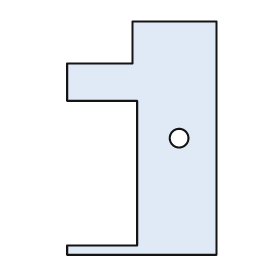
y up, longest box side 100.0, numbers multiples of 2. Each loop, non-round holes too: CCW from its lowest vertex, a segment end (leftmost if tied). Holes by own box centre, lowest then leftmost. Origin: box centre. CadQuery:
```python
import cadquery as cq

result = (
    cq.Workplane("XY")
    .moveTo(-32.0, -50.0)
    .lineTo(32.0, -50.0)
    .lineTo(32.0, 50.0)
    .lineTo(-4.0, 50.0)
    .lineTo(-4.0, 32.0)
    .lineTo(-32.0, 32.0)
    .lineTo(-32.0, 16.0)
    .lineTo(-2.0, 16.0)
    .lineTo(-2.0, -46.0)
    .lineTo(-32.0, -46.0)
    .close()
    .moveTo(16.0, 0.0)
    .circle(4.0)
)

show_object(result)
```